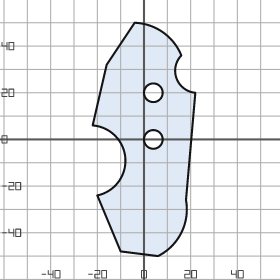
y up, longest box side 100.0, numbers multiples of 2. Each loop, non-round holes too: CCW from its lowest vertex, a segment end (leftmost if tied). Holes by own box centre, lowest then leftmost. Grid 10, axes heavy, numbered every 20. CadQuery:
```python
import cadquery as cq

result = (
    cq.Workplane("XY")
    .moveTo(6.0, -50.0)
    .threePointArc((16.0, -40.0), (18.0, -26.0))
    .lineTo(22.0, 20.0)
    .threePointArc((14.0, 26.0), (16.0, 36.0))
    .threePointArc((8.0, 46.0), (-4.0, 50.0))
    .lineTo(-16.0, 32.0)
    .lineTo(-22.0, 6.0)
    .threePointArc((-8.0, -8.0), (-20.0, -24.0))
    .lineTo(-10.0, -48.0)
    .close()
    .moveTo(4.0, 0.0)
    .circle(4.0)
    .moveTo(4.0, 20.0)
    .circle(4.0)
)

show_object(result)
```